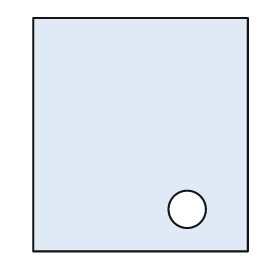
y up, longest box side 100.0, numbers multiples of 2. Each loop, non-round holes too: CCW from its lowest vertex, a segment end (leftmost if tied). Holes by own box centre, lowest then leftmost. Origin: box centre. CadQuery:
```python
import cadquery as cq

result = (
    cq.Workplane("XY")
    .moveTo(-46.0, -50.0)
    .lineTo(46.0, -50.0)
    .lineTo(46.0, 50.0)
    .lineTo(-46.0, 50.0)
    .close()
    .moveTo(20.0, -32.0)
    .circle(8.0)
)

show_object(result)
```